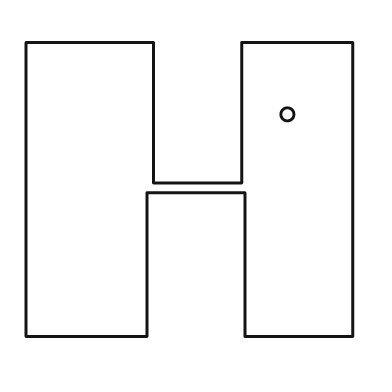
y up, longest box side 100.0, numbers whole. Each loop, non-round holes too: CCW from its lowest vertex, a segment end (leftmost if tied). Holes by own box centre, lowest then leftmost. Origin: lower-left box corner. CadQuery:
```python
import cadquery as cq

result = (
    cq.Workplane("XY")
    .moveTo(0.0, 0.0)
    .lineTo(37.0, 0.0)
    .lineTo(37.0, 44.0)
    .lineTo(67.0, 44.0)
    .lineTo(67.0, 0.0)
    .lineTo(100.0, 0.0)
    .lineTo(100.0, 90.0)
    .lineTo(66.0, 90.0)
    .lineTo(66.0, 47.0)
    .lineTo(39.0, 47.0)
    .lineTo(39.0, 90.0)
    .lineTo(0.0, 90.0)
    .close()
    .moveTo(80.0, 68.0)
    .circle(2.0)
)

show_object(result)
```